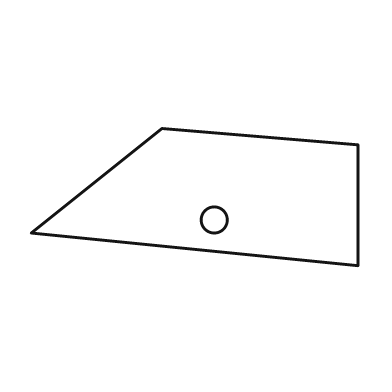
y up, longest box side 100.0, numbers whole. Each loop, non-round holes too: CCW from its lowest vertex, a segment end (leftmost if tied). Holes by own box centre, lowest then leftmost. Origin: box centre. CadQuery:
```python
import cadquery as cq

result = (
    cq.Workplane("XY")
    .moveTo(50.0, -21.0)
    .lineTo(50.0, 16.0)
    .lineTo(-10.0, 21.0)
    .lineTo(-50.0, -11.0)
    .close()
    .moveTo(6.0, -7.0)
    .circle(4.0)
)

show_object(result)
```